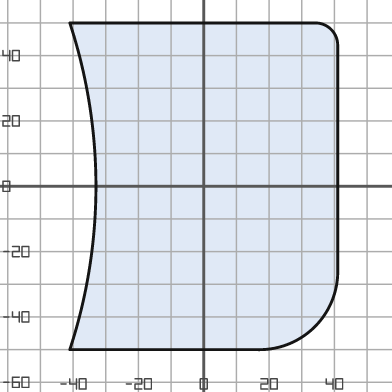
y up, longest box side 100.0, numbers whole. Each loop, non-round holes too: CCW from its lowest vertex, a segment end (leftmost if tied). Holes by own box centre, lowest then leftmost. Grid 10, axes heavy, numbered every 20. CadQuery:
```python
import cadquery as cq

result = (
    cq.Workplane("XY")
    .moveTo(-41.0, -50.0)
    .lineTo(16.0, -50.0)
    .threePointArc((34.0, -43.0), (41.0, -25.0))
    .lineTo(41.0, 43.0)
    .threePointArc((39.0, 48.0), (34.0, 50.0))
    .lineTo(-41.0, 50.0)
    .threePointArc((-33.0, 0.0), (-41.0, -50.0))
    .close()
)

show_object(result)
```